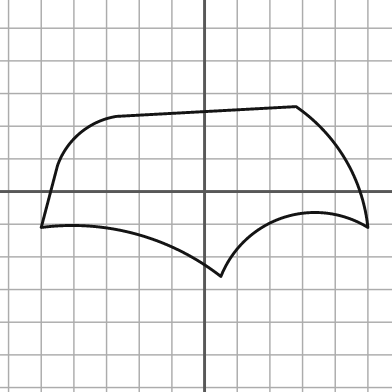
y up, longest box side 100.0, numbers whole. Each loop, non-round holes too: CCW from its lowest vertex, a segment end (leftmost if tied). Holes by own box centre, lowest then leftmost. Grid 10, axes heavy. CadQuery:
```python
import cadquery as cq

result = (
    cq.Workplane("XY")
    .moveTo(5.0, -26.0)
    .threePointArc((24.0, -8.0), (50.0, -11.0))
    .threePointArc((43.0, 10.0), (28.0, 26.0))
    .lineTo(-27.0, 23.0)
    .threePointArc((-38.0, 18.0), (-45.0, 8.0))
    .lineTo(-50.0, -11.0)
    .threePointArc((-21.0, -13.0), (5.0, -26.0))
    .close()
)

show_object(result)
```